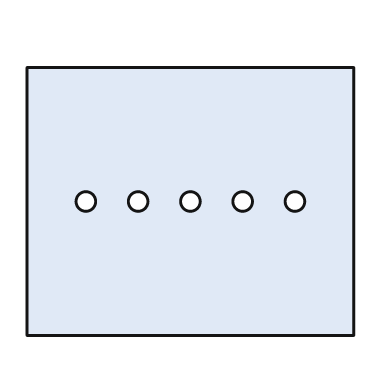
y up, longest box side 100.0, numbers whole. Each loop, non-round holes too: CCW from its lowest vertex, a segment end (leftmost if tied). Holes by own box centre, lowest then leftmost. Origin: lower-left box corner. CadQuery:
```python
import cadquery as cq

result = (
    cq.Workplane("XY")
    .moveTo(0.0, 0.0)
    .lineTo(100.0, 0.0)
    .lineTo(100.0, 82.0)
    .lineTo(0.0, 82.0)
    .close()
    .moveTo(18.0, 41.0)
    .circle(3.0)
    .moveTo(34.0, 41.0)
    .circle(3.0)
    .moveTo(50.0, 41.0)
    .circle(3.0)
    .moveTo(66.0, 41.0)
    .circle(3.0)
    .moveTo(82.0, 41.0)
    .circle(3.0)
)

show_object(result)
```